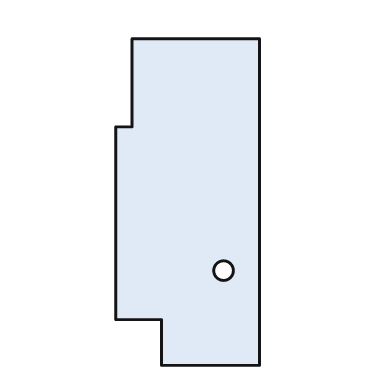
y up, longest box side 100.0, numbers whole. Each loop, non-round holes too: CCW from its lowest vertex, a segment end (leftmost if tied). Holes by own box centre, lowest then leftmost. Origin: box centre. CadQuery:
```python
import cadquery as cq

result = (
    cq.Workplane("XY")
    .moveTo(-8.0, -50.0)
    .lineTo(22.0, -50.0)
    .lineTo(22.0, 50.0)
    .lineTo(-17.0, 50.0)
    .lineTo(-17.0, 23.0)
    .lineTo(-22.0, 23.0)
    .lineTo(-22.0, -36.0)
    .lineTo(-8.0, -36.0)
    .close()
    .moveTo(11.0, -21.0)
    .circle(3.0)
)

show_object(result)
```